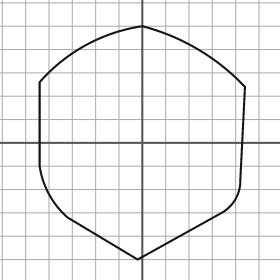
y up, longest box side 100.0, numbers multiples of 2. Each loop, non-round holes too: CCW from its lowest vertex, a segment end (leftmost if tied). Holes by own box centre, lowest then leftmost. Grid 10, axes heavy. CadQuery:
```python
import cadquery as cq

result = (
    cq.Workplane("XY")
    .moveTo(-2.0, -50.0)
    .lineTo(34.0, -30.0)
    .threePointArc((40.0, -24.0), (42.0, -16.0))
    .lineTo(44.0, 24.0)
    .threePointArc((24.0, 40.0), (0.0, 50.0))
    .threePointArc((-24.0, 42.0), (-44.0, 26.0))
    .lineTo(-44.0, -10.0)
    .threePointArc((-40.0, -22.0), (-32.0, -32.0))
    .close()
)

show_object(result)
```